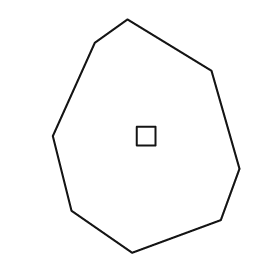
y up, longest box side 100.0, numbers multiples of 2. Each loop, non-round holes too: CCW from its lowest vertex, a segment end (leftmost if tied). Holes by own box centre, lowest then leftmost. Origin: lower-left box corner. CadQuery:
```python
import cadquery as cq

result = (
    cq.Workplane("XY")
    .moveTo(34.0, 0.0)
    .lineTo(72.0, 14.0)
    .lineTo(80.0, 36.0)
    .lineTo(68.0, 78.0)
    .lineTo(32.0, 100.0)
    .lineTo(18.0, 90.0)
    .lineTo(0.0, 50.0)
    .lineTo(8.0, 18.0)
    .close()
    .moveTo(36.0, 46.0)
    .lineTo(44.0, 46.0)
    .lineTo(44.0, 54.0)
    .lineTo(36.0, 54.0)
    .close()
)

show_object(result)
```